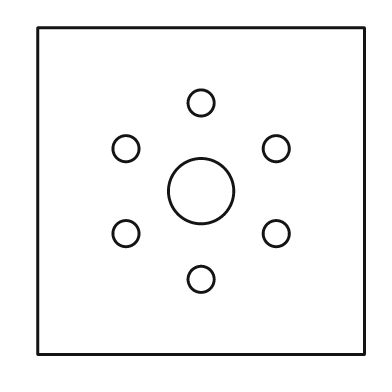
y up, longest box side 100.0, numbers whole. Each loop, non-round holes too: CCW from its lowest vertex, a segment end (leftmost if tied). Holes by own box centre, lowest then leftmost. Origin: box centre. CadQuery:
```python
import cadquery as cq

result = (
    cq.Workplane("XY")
    .moveTo(-50.0, -50.0)
    .lineTo(50.0, -50.0)
    .lineTo(50.0, 50.0)
    .lineTo(-50.0, 50.0)
    .close()
    .moveTo(0.0, -27.0)
    .circle(4.0)
    .moveTo(-23.0, -13.0)
    .circle(4.0)
    .moveTo(23.0, -13.0)
    .circle(4.0)
    .moveTo(0.0, 0.0)
    .circle(10.0)
    .moveTo(-23.0, 13.0)
    .circle(4.0)
    .moveTo(23.0, 13.0)
    .circle(4.0)
    .moveTo(0.0, 27.0)
    .circle(4.0)
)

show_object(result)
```